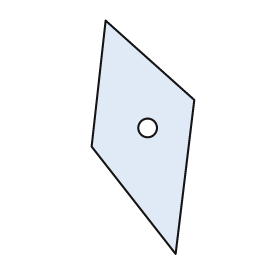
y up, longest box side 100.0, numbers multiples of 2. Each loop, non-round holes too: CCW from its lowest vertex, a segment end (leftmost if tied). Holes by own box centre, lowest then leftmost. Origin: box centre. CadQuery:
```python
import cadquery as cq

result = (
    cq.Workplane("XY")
    .moveTo(14.0, -50.0)
    .lineTo(22.0, 16.0)
    .lineTo(-16.0, 50.0)
    .lineTo(-22.0, -4.0)
    .close()
    .moveTo(2.0, 4.0)
    .circle(4.0)
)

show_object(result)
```